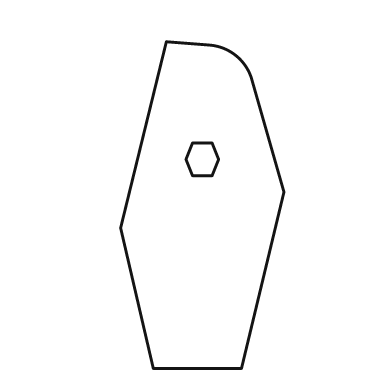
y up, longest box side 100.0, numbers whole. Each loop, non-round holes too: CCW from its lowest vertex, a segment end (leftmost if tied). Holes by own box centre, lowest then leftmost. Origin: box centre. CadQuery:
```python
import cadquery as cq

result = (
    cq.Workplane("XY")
    .moveTo(-15.0, -50.0)
    .lineTo(12.0, -50.0)
    .lineTo(25.0, 4.0)
    .lineTo(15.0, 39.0)
    .threePointArc((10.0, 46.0), (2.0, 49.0))
    .lineTo(-11.0, 50.0)
    .lineTo(-25.0, -7.0)
    .close()
    .moveTo(-3.0, 9.0)
    .lineTo(3.0, 9.0)
    .lineTo(5.0, 14.0)
    .lineTo(3.0, 19.0)
    .lineTo(-3.0, 19.0)
    .lineTo(-5.0, 14.0)
    .close()
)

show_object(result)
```